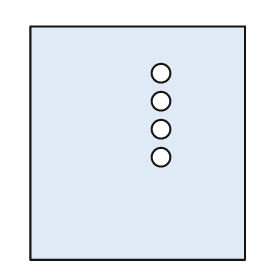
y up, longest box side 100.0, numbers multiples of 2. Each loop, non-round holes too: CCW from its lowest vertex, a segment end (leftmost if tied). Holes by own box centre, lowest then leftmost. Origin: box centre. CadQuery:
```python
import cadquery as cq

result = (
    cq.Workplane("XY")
    .moveTo(-46.0, -50.0)
    .lineTo(46.0, -50.0)
    .lineTo(46.0, 50.0)
    .lineTo(-46.0, 50.0)
    .close()
    .moveTo(10.0, -6.0)
    .circle(4.0)
    .moveTo(10.0, 6.0)
    .circle(4.0)
    .moveTo(10.0, 18.0)
    .circle(4.0)
    .moveTo(10.0, 30.0)
    .circle(4.0)
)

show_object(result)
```